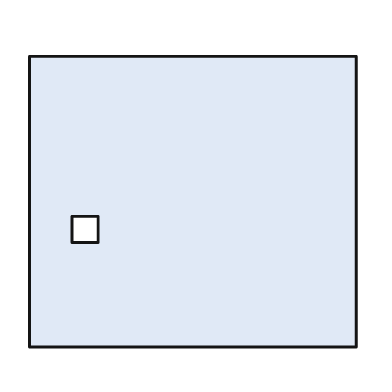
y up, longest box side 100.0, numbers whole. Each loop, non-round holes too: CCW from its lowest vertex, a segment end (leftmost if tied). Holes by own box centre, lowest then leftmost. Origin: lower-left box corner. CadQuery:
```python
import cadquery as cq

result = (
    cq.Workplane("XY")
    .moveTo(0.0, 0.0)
    .lineTo(100.0, 0.0)
    .lineTo(100.0, 89.0)
    .lineTo(0.0, 89.0)
    .close()
    .moveTo(13.0, 32.0)
    .lineTo(21.0, 32.0)
    .lineTo(21.0, 40.0)
    .lineTo(13.0, 40.0)
    .close()
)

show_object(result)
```